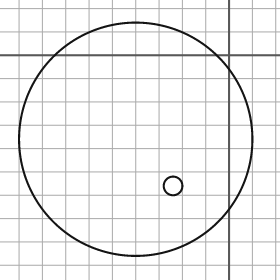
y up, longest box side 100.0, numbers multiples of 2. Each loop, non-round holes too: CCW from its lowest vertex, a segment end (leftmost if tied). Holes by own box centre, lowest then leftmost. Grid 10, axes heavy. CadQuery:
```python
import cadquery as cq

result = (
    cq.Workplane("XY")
    .moveTo(-40.0, -36.0)
    .circle(50.0)
    .moveTo(-24.0, -56.0)
    .circle(4.0)
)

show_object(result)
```